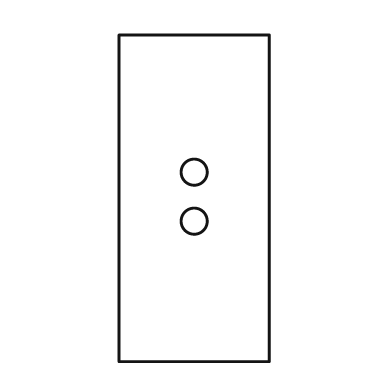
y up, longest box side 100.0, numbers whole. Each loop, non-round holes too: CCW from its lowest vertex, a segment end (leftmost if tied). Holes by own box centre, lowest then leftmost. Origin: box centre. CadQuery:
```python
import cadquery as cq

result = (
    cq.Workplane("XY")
    .moveTo(-23.0, -50.0)
    .lineTo(23.0, -50.0)
    .lineTo(23.0, 50.0)
    .lineTo(-23.0, 50.0)
    .close()
    .moveTo(0.0, -7.0)
    .circle(4.0)
    .moveTo(0.0, 8.0)
    .circle(4.0)
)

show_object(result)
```